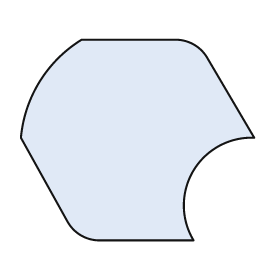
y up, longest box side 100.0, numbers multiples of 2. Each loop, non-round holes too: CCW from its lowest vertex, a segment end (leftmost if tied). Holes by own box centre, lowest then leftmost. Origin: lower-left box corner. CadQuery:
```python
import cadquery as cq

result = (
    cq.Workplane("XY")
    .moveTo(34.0, 0.0)
    .lineTo(74.0, 0.0)
    .threePointArc((74.0, 30.0), (100.0, 44.0))
    .lineTo(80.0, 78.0)
    .threePointArc((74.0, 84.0), (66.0, 86.0))
    .lineTo(26.0, 86.0)
    .threePointArc((8.0, 68.0), (0.0, 44.0))
    .lineTo(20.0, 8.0)
    .threePointArc((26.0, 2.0), (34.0, 0.0))
    .close()
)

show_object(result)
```